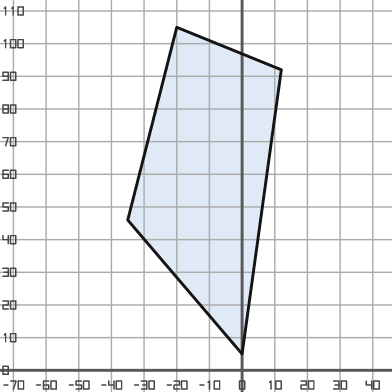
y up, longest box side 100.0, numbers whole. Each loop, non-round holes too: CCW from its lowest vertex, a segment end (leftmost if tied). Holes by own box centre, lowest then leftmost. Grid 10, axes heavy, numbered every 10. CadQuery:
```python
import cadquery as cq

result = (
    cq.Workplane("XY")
    .moveTo(0.0, 5.0)
    .lineTo(12.0, 92.0)
    .lineTo(-20.0, 105.0)
    .lineTo(-35.0, 46.0)
    .close()
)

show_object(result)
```